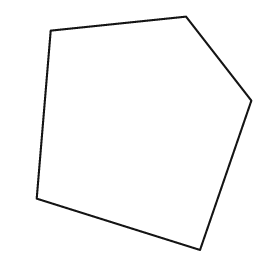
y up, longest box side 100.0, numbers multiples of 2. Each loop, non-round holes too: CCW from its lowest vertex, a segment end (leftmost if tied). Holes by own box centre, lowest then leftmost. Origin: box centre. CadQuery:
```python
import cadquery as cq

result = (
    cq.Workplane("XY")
    .moveTo(24.0, -50.0)
    .lineTo(46.0, 14.0)
    .lineTo(18.0, 50.0)
    .lineTo(-40.0, 44.0)
    .lineTo(-46.0, -28.0)
    .close()
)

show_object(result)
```